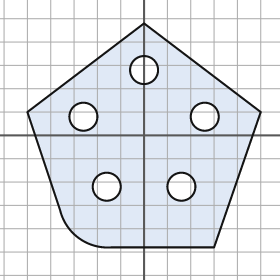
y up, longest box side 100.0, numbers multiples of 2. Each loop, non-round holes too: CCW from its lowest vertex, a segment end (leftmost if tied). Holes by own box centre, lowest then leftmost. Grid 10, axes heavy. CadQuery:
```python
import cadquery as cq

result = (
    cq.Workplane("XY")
    .moveTo(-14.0, -48.0)
    .lineTo(30.0, -48.0)
    .lineTo(50.0, 10.0)
    .lineTo(0.0, 48.0)
    .lineTo(-50.0, 10.0)
    .lineTo(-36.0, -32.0)
    .threePointArc((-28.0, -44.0), (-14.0, -48.0))
    .close()
    .moveTo(-16.0, -22.0)
    .circle(6.0)
    .moveTo(16.0, -22.0)
    .circle(6.0)
    .moveTo(-26.0, 8.0)
    .circle(6.0)
    .moveTo(26.0, 8.0)
    .circle(6.0)
    .moveTo(0.0, 28.0)
    .circle(6.0)
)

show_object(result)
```